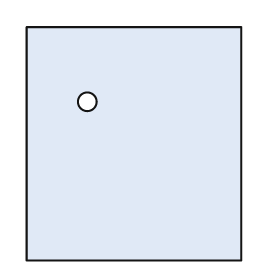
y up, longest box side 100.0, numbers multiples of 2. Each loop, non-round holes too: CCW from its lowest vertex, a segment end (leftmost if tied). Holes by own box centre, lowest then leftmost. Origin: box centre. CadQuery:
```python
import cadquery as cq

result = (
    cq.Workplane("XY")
    .moveTo(-46.0, -50.0)
    .lineTo(46.0, -50.0)
    .lineTo(46.0, 50.0)
    .lineTo(-46.0, 50.0)
    .close()
    .moveTo(-20.0, 18.0)
    .circle(4.0)
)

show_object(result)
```